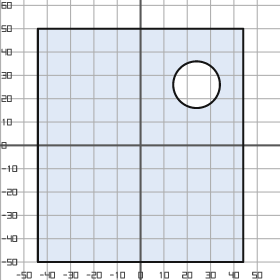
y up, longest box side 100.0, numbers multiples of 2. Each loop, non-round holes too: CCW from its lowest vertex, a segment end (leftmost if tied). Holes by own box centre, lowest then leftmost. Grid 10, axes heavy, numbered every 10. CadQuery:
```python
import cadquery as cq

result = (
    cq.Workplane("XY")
    .moveTo(-44.0, -50.0)
    .lineTo(44.0, -50.0)
    .lineTo(44.0, 50.0)
    .lineTo(-44.0, 50.0)
    .close()
    .moveTo(24.0, 26.0)
    .circle(10.0)
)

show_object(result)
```